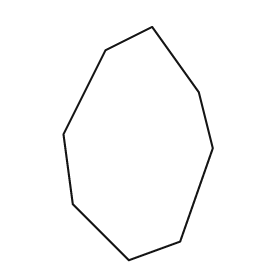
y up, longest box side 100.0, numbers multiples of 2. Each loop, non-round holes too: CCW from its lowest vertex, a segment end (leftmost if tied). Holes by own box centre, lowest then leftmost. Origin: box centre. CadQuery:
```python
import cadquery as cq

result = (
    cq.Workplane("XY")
    .moveTo(-4.0, -50.0)
    .lineTo(18.0, -42.0)
    .lineTo(32.0, -2.0)
    .lineTo(26.0, 22.0)
    .lineTo(6.0, 50.0)
    .lineTo(-14.0, 40.0)
    .lineTo(-32.0, 4.0)
    .lineTo(-28.0, -26.0)
    .close()
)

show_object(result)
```